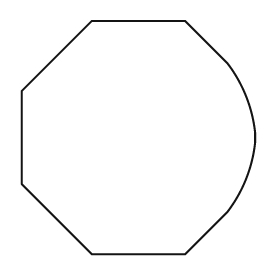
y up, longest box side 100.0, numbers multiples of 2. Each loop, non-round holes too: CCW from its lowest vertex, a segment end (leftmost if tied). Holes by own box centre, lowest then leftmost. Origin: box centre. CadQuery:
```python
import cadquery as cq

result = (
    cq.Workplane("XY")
    .moveTo(-20.0, -50.0)
    .lineTo(20.0, -50.0)
    .lineTo(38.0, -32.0)
    .threePointArc((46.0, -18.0), (50.0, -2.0))
    .lineTo(50.0, 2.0)
    .threePointArc((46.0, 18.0), (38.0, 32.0))
    .lineTo(20.0, 50.0)
    .lineTo(-20.0, 50.0)
    .lineTo(-50.0, 20.0)
    .lineTo(-50.0, -20.0)
    .close()
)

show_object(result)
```